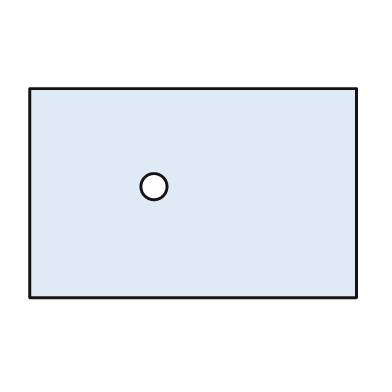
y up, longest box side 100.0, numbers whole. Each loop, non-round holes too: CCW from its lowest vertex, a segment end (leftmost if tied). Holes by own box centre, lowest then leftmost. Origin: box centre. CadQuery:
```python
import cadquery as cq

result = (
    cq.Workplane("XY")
    .moveTo(-50.0, -32.0)
    .lineTo(50.0, -32.0)
    .lineTo(50.0, 32.0)
    .lineTo(-50.0, 32.0)
    .close()
    .moveTo(-12.0, 2.0)
    .circle(4.0)
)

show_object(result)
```